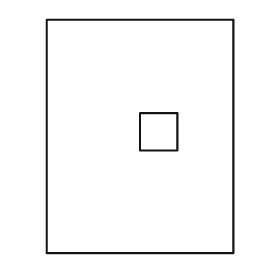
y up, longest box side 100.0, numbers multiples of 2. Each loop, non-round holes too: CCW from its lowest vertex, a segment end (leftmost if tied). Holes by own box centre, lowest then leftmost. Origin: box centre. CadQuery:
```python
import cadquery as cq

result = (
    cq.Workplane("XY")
    .moveTo(-40.0, -50.0)
    .lineTo(40.0, -50.0)
    .lineTo(40.0, 50.0)
    .lineTo(-40.0, 50.0)
    .close()
    .moveTo(0.0, -6.0)
    .lineTo(16.0, -6.0)
    .lineTo(16.0, 10.0)
    .lineTo(0.0, 10.0)
    .close()
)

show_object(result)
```